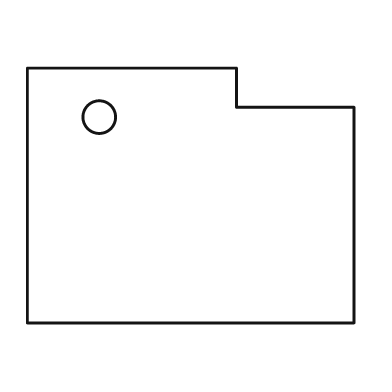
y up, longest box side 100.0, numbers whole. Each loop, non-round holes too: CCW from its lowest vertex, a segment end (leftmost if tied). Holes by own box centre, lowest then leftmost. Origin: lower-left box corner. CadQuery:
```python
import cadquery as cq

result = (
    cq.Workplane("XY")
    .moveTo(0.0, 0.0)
    .lineTo(100.0, 0.0)
    .lineTo(100.0, 66.0)
    .lineTo(64.0, 66.0)
    .lineTo(64.0, 78.0)
    .lineTo(0.0, 78.0)
    .close()
    .moveTo(22.0, 63.0)
    .circle(5.0)
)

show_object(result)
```